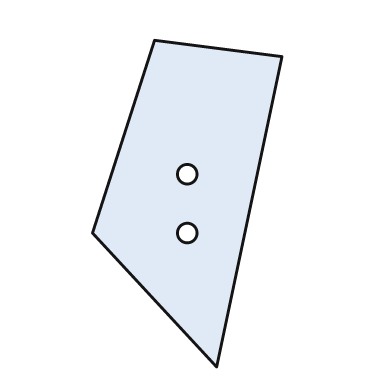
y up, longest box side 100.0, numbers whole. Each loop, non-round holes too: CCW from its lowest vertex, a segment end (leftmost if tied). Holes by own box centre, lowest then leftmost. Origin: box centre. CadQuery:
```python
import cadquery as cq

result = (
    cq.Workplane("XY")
    .moveTo(9.0, -50.0)
    .lineTo(29.0, 45.0)
    .lineTo(-10.0, 50.0)
    .lineTo(-29.0, -9.0)
    .close()
    .moveTo(0.0, -9.0)
    .circle(3.0)
    .moveTo(0.0, 9.0)
    .circle(3.0)
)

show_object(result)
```